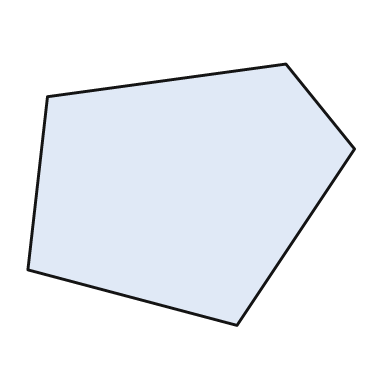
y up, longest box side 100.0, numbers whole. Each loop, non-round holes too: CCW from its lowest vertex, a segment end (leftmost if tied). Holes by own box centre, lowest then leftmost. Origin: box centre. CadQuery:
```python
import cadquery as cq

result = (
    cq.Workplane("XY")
    .moveTo(14.0, -40.0)
    .lineTo(50.0, 14.0)
    .lineTo(29.0, 40.0)
    .lineTo(-44.0, 30.0)
    .lineTo(-50.0, -23.0)
    .close()
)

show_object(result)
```